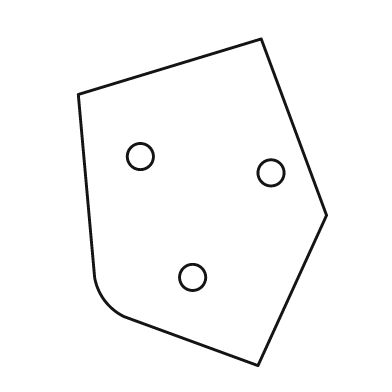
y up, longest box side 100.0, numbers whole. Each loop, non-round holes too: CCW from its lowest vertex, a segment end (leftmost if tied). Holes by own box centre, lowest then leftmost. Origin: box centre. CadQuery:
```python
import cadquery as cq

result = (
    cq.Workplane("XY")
    .moveTo(17.0, -50.0)
    .lineTo(38.0, -4.0)
    .lineTo(18.0, 50.0)
    .lineTo(-38.0, 33.0)
    .lineTo(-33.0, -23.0)
    .threePointArc((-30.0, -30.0), (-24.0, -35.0))
    .close()
    .moveTo(-3.0, -23.0)
    .circle(4.0)
    .moveTo(21.0, 9.0)
    .circle(4.0)
    .moveTo(-19.0, 14.0)
    .circle(4.0)
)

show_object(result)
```